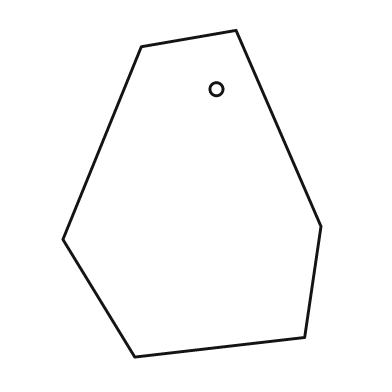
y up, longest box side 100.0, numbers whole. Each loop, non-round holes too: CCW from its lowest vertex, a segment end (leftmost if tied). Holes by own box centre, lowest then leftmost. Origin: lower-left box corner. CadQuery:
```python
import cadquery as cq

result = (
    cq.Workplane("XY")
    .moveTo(22.0, 0.0)
    .lineTo(74.0, 6.0)
    .lineTo(79.0, 40.0)
    .lineTo(53.0, 100.0)
    .lineTo(24.0, 95.0)
    .lineTo(0.0, 36.0)
    .close()
    .moveTo(47.0, 82.0)
    .circle(2.0)
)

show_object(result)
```